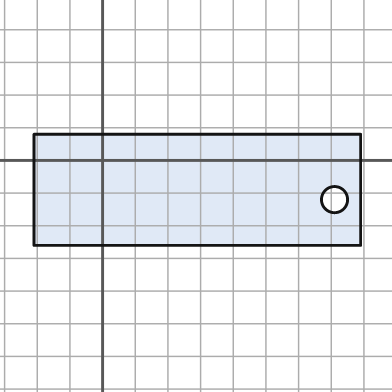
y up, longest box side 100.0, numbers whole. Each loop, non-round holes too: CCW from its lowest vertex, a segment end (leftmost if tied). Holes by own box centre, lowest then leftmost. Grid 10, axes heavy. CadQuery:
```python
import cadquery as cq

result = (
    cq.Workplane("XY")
    .moveTo(-21.0, -26.0)
    .lineTo(79.0, -26.0)
    .lineTo(79.0, 8.0)
    .lineTo(-21.0, 8.0)
    .close()
    .moveTo(71.0, -12.0)
    .circle(4.0)
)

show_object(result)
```